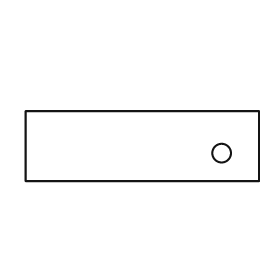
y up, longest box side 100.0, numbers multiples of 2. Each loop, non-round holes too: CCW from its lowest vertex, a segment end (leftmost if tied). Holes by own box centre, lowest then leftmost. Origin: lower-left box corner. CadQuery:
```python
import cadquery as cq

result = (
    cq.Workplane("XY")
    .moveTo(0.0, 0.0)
    .lineTo(100.0, 0.0)
    .lineTo(100.0, 30.0)
    .lineTo(0.0, 30.0)
    .close()
    .moveTo(84.0, 12.0)
    .circle(4.0)
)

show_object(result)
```